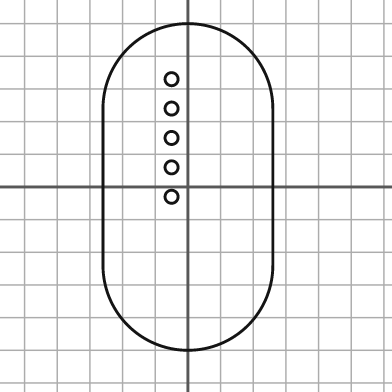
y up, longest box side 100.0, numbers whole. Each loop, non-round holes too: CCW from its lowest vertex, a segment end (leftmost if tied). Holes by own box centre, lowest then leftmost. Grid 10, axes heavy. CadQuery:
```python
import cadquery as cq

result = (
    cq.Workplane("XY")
    .moveTo(-26.0, -24.0)
    .threePointArc((0.0, -50.0), (26.0, -24.0))
    .lineTo(26.0, 24.0)
    .threePointArc((0.0, 50.0), (-26.0, 24.0))
    .close()
    .moveTo(-5.0, -3.0)
    .circle(2.0)
    .moveTo(-5.0, 6.0)
    .circle(2.0)
    .moveTo(-5.0, 15.0)
    .circle(2.0)
    .moveTo(-5.0, 24.0)
    .circle(2.0)
    .moveTo(-5.0, 33.0)
    .circle(2.0)
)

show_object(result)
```